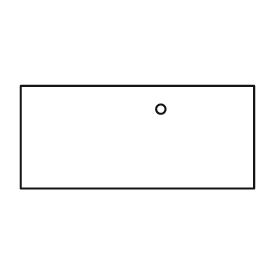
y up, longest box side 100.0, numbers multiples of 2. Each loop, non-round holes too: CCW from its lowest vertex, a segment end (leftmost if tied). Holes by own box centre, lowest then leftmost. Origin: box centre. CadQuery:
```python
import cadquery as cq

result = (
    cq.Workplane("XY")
    .moveTo(-50.0, -22.0)
    .lineTo(50.0, -22.0)
    .lineTo(50.0, 22.0)
    .lineTo(-50.0, 22.0)
    .close()
    .moveTo(10.0, 12.0)
    .circle(2.0)
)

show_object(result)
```